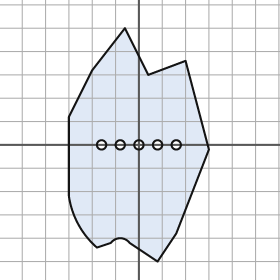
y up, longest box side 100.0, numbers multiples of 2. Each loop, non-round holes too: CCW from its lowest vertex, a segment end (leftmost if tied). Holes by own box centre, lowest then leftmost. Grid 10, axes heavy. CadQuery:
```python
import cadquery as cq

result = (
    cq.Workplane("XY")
    .moveTo(8.0, -50.0)
    .lineTo(16.0, -38.0)
    .lineTo(30.0, -2.0)
    .lineTo(20.0, 36.0)
    .lineTo(4.0, 30.0)
    .lineTo(-6.0, 50.0)
    .lineTo(-20.0, 32.0)
    .lineTo(-30.0, 12.0)
    .lineTo(-30.0, -22.0)
    .threePointArc((-26.0, -34.0), (-18.0, -44.0))
    .lineTo(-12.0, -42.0)
    .threePointArc((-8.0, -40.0), (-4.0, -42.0))
    .close()
    .moveTo(-16.0, 0.0)
    .circle(2.0)
    .moveTo(-8.0, 0.0)
    .circle(2.0)
    .moveTo(0.0, 0.0)
    .circle(2.0)
    .moveTo(8.0, 0.0)
    .circle(2.0)
    .moveTo(16.0, 0.0)
    .circle(2.0)
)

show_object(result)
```